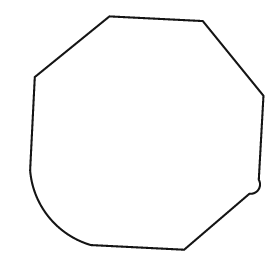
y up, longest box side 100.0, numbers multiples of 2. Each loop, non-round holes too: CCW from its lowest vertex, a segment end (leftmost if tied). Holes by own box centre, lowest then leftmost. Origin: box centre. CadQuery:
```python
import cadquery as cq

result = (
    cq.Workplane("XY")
    .moveTo(16.0, -50.0)
    .lineTo(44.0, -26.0)
    .threePointArc((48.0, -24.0), (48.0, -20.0))
    .lineTo(50.0, 16.0)
    .lineTo(24.0, 48.0)
    .lineTo(-16.0, 50.0)
    .lineTo(-48.0, 24.0)
    .lineTo(-50.0, -16.0)
    .threePointArc((-42.0, -36.0), (-24.0, -48.0))
    .close()
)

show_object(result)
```